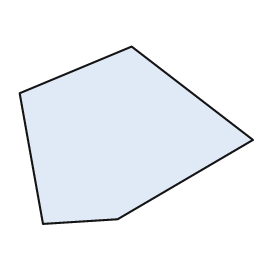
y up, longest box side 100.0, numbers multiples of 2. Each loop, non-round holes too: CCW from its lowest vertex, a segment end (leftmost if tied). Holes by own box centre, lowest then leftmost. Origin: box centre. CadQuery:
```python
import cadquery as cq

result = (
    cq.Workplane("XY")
    .moveTo(-40.0, -38.0)
    .lineTo(-8.0, -36.0)
    .lineTo(50.0, -2.0)
    .lineTo(-2.0, 38.0)
    .lineTo(-50.0, 18.0)
    .close()
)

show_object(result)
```